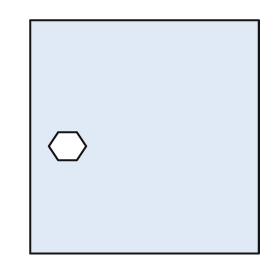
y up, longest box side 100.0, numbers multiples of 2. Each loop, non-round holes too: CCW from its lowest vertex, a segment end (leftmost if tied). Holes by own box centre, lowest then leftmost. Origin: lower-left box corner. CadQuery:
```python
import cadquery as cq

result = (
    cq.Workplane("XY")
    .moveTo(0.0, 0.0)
    .lineTo(98.0, 0.0)
    .lineTo(98.0, 100.0)
    .lineTo(0.0, 100.0)
    .close()
    .moveTo(12.0, 40.0)
    .lineTo(20.0, 40.0)
    .lineTo(24.0, 46.0)
    .lineTo(20.0, 52.0)
    .lineTo(12.0, 52.0)
    .lineTo(8.0, 46.0)
    .close()
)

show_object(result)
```